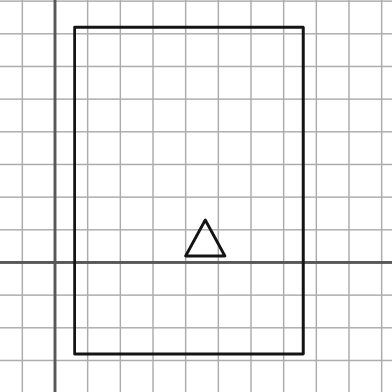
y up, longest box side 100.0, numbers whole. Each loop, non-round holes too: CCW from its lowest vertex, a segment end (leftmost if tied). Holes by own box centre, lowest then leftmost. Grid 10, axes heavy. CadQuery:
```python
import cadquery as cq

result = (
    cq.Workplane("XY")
    .moveTo(6.0, -28.0)
    .lineTo(76.0, -28.0)
    .lineTo(76.0, 72.0)
    .lineTo(6.0, 72.0)
    .close()
    .moveTo(40.0, 2.0)
    .lineTo(52.0, 2.0)
    .lineTo(46.0, 13.0)
    .close()
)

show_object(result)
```